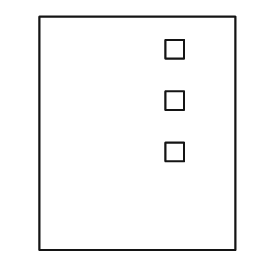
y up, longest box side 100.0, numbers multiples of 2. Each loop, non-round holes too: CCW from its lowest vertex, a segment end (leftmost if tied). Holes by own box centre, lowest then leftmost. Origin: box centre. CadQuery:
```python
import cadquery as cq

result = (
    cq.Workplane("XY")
    .moveTo(-42.0, -50.0)
    .lineTo(42.0, -50.0)
    .lineTo(42.0, 50.0)
    .lineTo(-42.0, 50.0)
    .close()
    .moveTo(12.0, -12.0)
    .lineTo(20.0, -12.0)
    .lineTo(20.0, -4.0)
    .lineTo(12.0, -4.0)
    .close()
    .moveTo(12.0, 10.0)
    .lineTo(20.0, 10.0)
    .lineTo(20.0, 18.0)
    .lineTo(12.0, 18.0)
    .close()
    .moveTo(12.0, 32.0)
    .lineTo(20.0, 32.0)
    .lineTo(20.0, 40.0)
    .lineTo(12.0, 40.0)
    .close()
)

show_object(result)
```